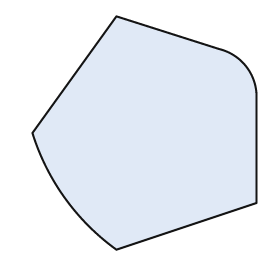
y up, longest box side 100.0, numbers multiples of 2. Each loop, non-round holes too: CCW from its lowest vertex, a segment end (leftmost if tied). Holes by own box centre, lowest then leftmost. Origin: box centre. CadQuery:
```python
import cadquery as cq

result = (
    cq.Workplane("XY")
    .moveTo(-12.0, -50.0)
    .lineTo(48.0, -30.0)
    .lineTo(48.0, 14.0)
    .threePointArc((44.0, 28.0), (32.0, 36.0))
    .lineTo(-12.0, 50.0)
    .lineTo(-48.0, 0.0)
    .threePointArc((-34.0, -28.0), (-12.0, -50.0))
    .close()
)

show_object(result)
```